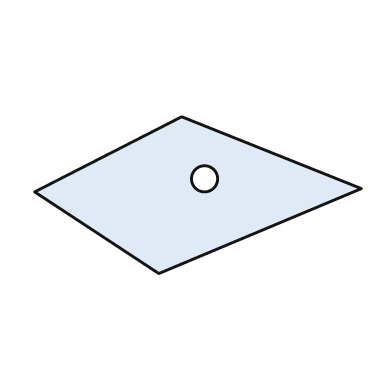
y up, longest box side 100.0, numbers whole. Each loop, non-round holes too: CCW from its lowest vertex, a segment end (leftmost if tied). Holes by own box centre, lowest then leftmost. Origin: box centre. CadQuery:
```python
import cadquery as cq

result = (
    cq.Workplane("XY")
    .moveTo(-12.0, -24.0)
    .lineTo(50.0, 2.0)
    .lineTo(-5.0, 24.0)
    .lineTo(-50.0, 1.0)
    .close()
    .moveTo(2.0, 5.0)
    .circle(4.0)
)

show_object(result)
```